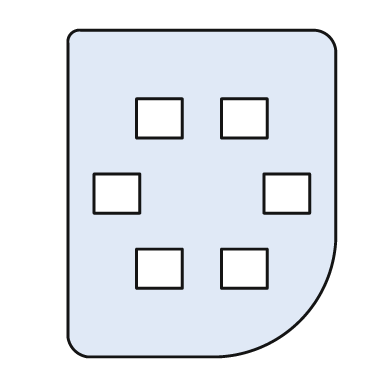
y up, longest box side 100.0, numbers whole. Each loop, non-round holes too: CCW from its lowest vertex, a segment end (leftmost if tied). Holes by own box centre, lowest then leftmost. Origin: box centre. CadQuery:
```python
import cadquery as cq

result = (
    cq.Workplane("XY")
    .moveTo(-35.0, -50.0)
    .lineTo(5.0, -50.0)
    .threePointArc((30.0, -39.0), (41.0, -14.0))
    .lineTo(41.0, 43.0)
    .threePointArc((39.0, 48.0), (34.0, 50.0))
    .lineTo(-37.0, 50.0)
    .threePointArc((-40.0, 49.0), (-41.0, 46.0))
    .lineTo(-41.0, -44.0)
    .threePointArc((-39.0, -48.0), (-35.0, -50.0))
    .close()
    .moveTo(-20.0, -29.0)
    .lineTo(-6.0, -29.0)
    .lineTo(-6.0, -17.0)
    .lineTo(-20.0, -17.0)
    .close()
    .moveTo(6.0, -29.0)
    .lineTo(20.0, -29.0)
    .lineTo(20.0, -17.0)
    .lineTo(6.0, -17.0)
    .close()
    .moveTo(-33.0, -6.0)
    .lineTo(-19.0, -6.0)
    .lineTo(-19.0, 6.0)
    .lineTo(-33.0, 6.0)
    .close()
    .moveTo(19.0, -6.0)
    .lineTo(33.0, -6.0)
    .lineTo(33.0, 6.0)
    .lineTo(19.0, 6.0)
    .close()
    .moveTo(-20.0, 17.0)
    .lineTo(-6.0, 17.0)
    .lineTo(-6.0, 29.0)
    .lineTo(-20.0, 29.0)
    .close()
    .moveTo(6.0, 17.0)
    .lineTo(20.0, 17.0)
    .lineTo(20.0, 29.0)
    .lineTo(6.0, 29.0)
    .close()
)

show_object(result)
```